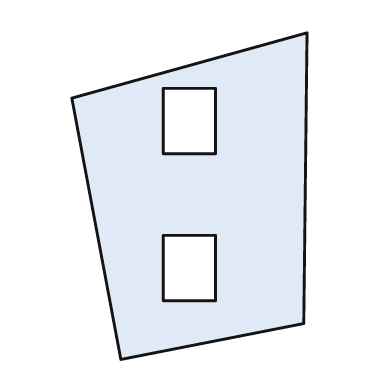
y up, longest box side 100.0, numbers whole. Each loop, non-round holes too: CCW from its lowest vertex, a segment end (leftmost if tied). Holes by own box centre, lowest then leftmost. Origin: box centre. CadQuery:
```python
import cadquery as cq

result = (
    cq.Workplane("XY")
    .moveTo(-21.0, -50.0)
    .lineTo(35.0, -39.0)
    .lineTo(36.0, 50.0)
    .lineTo(-36.0, 30.0)
    .close()
    .moveTo(-8.0, -32.0)
    .lineTo(8.0, -32.0)
    .lineTo(8.0, -12.0)
    .lineTo(-8.0, -12.0)
    .close()
    .moveTo(-8.0, 13.0)
    .lineTo(8.0, 13.0)
    .lineTo(8.0, 33.0)
    .lineTo(-8.0, 33.0)
    .close()
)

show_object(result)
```